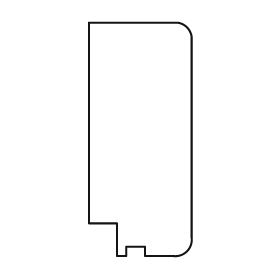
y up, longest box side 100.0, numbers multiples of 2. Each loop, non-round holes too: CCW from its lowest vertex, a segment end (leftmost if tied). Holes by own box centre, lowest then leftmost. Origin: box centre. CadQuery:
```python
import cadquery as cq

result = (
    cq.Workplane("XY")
    .moveTo(-10.0, -50.0)
    .lineTo(-6.0, -50.0)
    .lineTo(-6.0, -46.0)
    .lineTo(2.0, -46.0)
    .lineTo(2.0, -50.0)
    .lineTo(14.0, -50.0)
    .threePointArc((20.0, -48.0), (22.0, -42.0))
    .lineTo(22.0, 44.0)
    .threePointArc((20.0, 48.0), (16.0, 50.0))
    .lineTo(-22.0, 50.0)
    .lineTo(-22.0, -36.0)
    .lineTo(-10.0, -36.0)
    .close()
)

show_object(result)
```